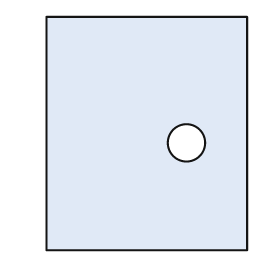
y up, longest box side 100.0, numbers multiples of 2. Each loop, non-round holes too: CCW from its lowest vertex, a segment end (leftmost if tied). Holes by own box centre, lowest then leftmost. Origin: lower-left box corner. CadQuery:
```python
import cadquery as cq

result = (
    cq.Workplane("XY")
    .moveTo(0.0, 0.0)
    .lineTo(86.0, 0.0)
    .lineTo(86.0, 100.0)
    .lineTo(0.0, 100.0)
    .close()
    .moveTo(60.0, 46.0)
    .circle(8.0)
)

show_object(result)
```